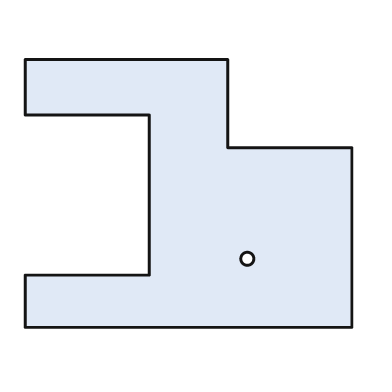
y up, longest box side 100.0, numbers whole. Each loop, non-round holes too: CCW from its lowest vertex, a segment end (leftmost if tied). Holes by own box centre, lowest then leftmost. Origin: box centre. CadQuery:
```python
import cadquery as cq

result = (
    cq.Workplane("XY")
    .moveTo(-50.0, -41.0)
    .lineTo(50.0, -41.0)
    .lineTo(50.0, 14.0)
    .lineTo(12.0, 14.0)
    .lineTo(12.0, 41.0)
    .lineTo(-50.0, 41.0)
    .lineTo(-50.0, 24.0)
    .lineTo(-12.0, 24.0)
    .lineTo(-12.0, -25.0)
    .lineTo(-50.0, -25.0)
    .close()
    .moveTo(18.0, -20.0)
    .circle(2.0)
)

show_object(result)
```